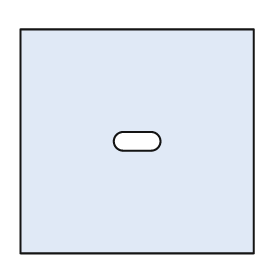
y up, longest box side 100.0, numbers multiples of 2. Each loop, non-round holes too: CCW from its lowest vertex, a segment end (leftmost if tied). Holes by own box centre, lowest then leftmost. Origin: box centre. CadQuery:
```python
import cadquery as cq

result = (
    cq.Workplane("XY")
    .moveTo(-50.0, -48.0)
    .lineTo(50.0, -48.0)
    .lineTo(50.0, 48.0)
    .lineTo(-50.0, 48.0)
    .close()
    .moveTo(-6.0, -4.0)
    .lineTo(6.0, -4.0)
    .threePointArc((10.0, 0.0), (6.0, 4.0))
    .lineTo(-6.0, 4.0)
    .threePointArc((-10.0, 0.0), (-6.0, -4.0))
    .close()
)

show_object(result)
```